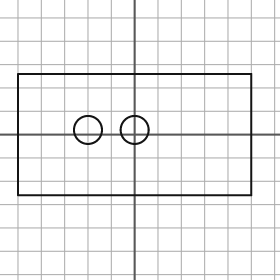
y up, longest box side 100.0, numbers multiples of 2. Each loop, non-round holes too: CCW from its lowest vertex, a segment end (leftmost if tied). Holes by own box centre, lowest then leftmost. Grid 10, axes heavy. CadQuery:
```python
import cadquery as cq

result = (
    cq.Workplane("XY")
    .moveTo(-50.0, -26.0)
    .lineTo(50.0, -26.0)
    .lineTo(50.0, 26.0)
    .lineTo(-50.0, 26.0)
    .close()
    .moveTo(-20.0, 2.0)
    .circle(6.0)
    .moveTo(0.0, 2.0)
    .circle(6.0)
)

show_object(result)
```